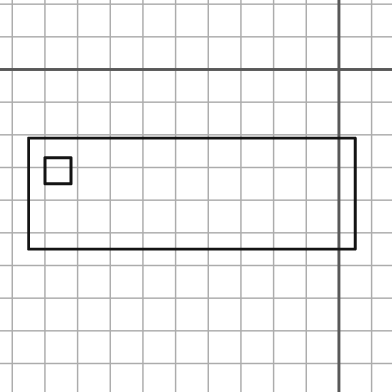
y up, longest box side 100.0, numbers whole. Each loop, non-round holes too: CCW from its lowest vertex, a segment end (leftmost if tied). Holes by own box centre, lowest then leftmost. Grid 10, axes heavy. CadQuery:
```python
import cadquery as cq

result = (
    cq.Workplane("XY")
    .moveTo(-95.0, -55.0)
    .lineTo(5.0, -55.0)
    .lineTo(5.0, -21.0)
    .lineTo(-95.0, -21.0)
    .close()
    .moveTo(-90.0, -35.0)
    .lineTo(-82.0, -35.0)
    .lineTo(-82.0, -27.0)
    .lineTo(-90.0, -27.0)
    .close()
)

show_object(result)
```